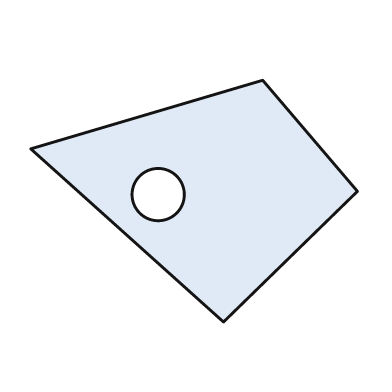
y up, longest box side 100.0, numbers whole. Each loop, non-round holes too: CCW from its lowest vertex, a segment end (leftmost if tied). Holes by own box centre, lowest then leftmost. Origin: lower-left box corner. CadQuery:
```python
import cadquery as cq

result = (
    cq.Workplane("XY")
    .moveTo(59.0, 0.0)
    .lineTo(100.0, 40.0)
    .lineTo(71.0, 74.0)
    .lineTo(0.0, 53.0)
    .close()
    .moveTo(39.0, 39.0)
    .circle(8.0)
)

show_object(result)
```